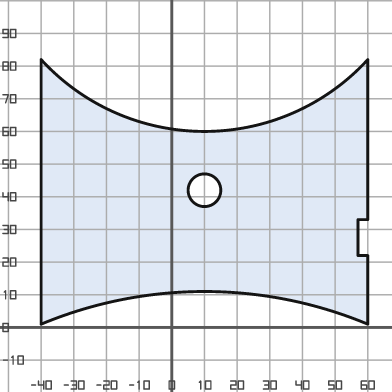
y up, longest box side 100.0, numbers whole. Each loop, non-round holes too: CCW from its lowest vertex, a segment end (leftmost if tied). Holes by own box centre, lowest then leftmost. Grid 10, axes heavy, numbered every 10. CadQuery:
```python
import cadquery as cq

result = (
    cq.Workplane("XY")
    .moveTo(-40.0, 1.0)
    .threePointArc((10.0, 11.0), (60.0, 1.0))
    .lineTo(60.0, 22.0)
    .lineTo(57.0, 22.0)
    .lineTo(57.0, 33.0)
    .lineTo(60.0, 33.0)
    .lineTo(60.0, 82.0)
    .threePointArc((10.0, 60.0), (-40.0, 82.0))
    .close()
    .moveTo(10.0, 42.0)
    .circle(5.0)
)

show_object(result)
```